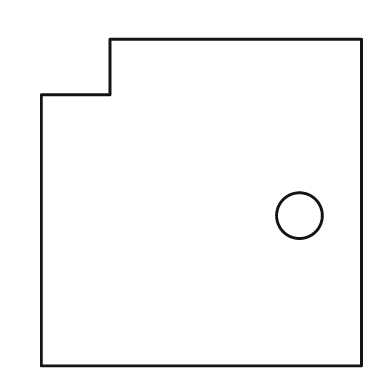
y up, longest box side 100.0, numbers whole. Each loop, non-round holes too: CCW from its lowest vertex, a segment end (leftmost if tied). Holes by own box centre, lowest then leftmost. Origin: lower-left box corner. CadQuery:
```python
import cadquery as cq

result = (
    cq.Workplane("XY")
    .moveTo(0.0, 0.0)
    .lineTo(98.0, 0.0)
    .lineTo(98.0, 100.0)
    .lineTo(21.0, 100.0)
    .lineTo(21.0, 83.0)
    .lineTo(0.0, 83.0)
    .close()
    .moveTo(79.0, 46.0)
    .circle(7.0)
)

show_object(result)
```